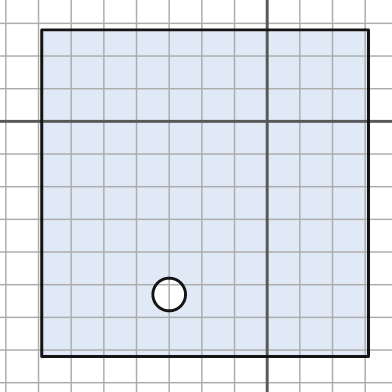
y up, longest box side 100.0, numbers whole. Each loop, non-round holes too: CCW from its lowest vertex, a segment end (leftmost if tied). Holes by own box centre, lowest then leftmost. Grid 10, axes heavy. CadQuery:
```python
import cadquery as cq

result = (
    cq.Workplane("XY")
    .moveTo(-69.0, -72.0)
    .lineTo(31.0, -72.0)
    .lineTo(31.0, 28.0)
    .lineTo(-69.0, 28.0)
    .close()
    .moveTo(-30.0, -53.0)
    .circle(5.0)
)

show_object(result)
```